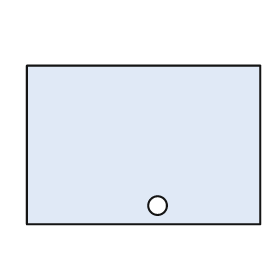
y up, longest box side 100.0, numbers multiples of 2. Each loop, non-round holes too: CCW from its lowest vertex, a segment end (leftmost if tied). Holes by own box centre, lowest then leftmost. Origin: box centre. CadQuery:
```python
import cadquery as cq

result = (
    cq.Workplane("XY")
    .moveTo(-50.0, -34.0)
    .lineTo(50.0, -34.0)
    .lineTo(50.0, 34.0)
    .lineTo(-50.0, 34.0)
    .close()
    .moveTo(6.0, -26.0)
    .circle(4.0)
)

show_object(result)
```